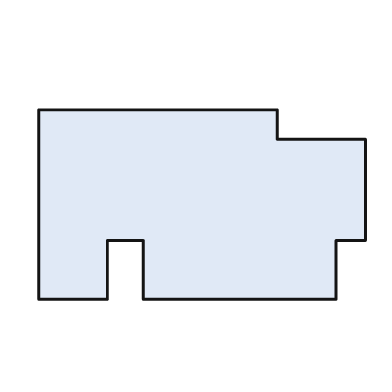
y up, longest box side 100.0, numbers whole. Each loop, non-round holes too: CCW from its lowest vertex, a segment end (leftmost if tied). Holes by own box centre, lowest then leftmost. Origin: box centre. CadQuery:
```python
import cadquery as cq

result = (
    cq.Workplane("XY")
    .moveTo(-50.0, -29.0)
    .lineTo(-29.0, -29.0)
    .lineTo(-29.0, -11.0)
    .lineTo(-18.0, -11.0)
    .lineTo(-18.0, -29.0)
    .lineTo(41.0, -29.0)
    .lineTo(41.0, -11.0)
    .lineTo(50.0, -11.0)
    .lineTo(50.0, 20.0)
    .lineTo(23.0, 20.0)
    .lineTo(23.0, 29.0)
    .lineTo(-50.0, 29.0)
    .close()
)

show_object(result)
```